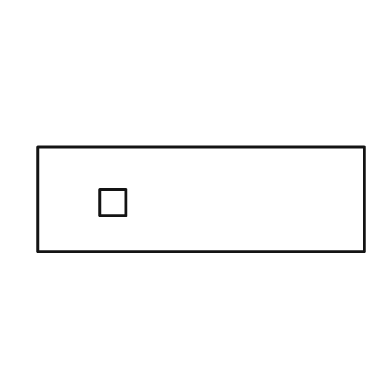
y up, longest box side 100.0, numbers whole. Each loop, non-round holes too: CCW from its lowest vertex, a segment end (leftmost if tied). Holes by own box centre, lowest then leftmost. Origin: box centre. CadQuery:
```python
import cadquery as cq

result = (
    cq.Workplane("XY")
    .moveTo(-50.0, -16.0)
    .lineTo(50.0, -16.0)
    .lineTo(50.0, 16.0)
    .lineTo(-50.0, 16.0)
    .close()
    .moveTo(-31.0, -5.0)
    .lineTo(-23.0, -5.0)
    .lineTo(-23.0, 3.0)
    .lineTo(-31.0, 3.0)
    .close()
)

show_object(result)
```